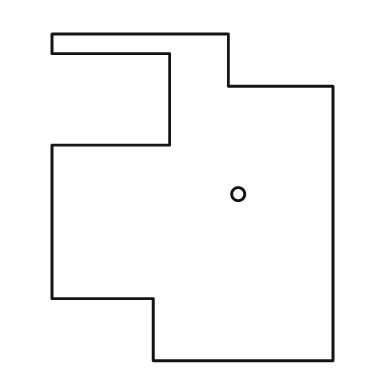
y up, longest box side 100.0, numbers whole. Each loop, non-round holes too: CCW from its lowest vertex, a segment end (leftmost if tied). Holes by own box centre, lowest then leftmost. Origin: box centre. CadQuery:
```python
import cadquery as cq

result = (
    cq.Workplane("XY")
    .moveTo(-12.0, -50.0)
    .lineTo(43.0, -50.0)
    .lineTo(43.0, 34.0)
    .lineTo(11.0, 34.0)
    .lineTo(11.0, 50.0)
    .lineTo(-43.0, 50.0)
    .lineTo(-43.0, 44.0)
    .lineTo(-7.0, 44.0)
    .lineTo(-7.0, 16.0)
    .lineTo(-43.0, 16.0)
    .lineTo(-43.0, -31.0)
    .lineTo(-12.0, -31.0)
    .close()
    .moveTo(14.0, 1.0)
    .circle(2.0)
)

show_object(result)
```